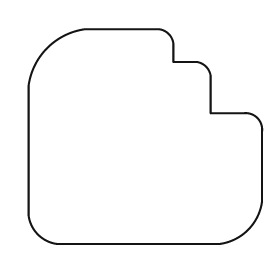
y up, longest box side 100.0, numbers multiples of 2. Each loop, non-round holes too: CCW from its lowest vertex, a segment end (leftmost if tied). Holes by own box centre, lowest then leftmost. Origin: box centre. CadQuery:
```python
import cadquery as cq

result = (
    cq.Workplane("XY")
    .moveTo(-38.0, -46.0)
    .lineTo(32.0, -46.0)
    .threePointArc((44.0, -40.0), (50.0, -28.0))
    .lineTo(50.0, 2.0)
    .threePointArc((48.0, 8.0), (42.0, 10.0))
    .lineTo(28.0, 10.0)
    .lineTo(28.0, 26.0)
    .threePointArc((26.0, 30.0), (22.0, 32.0))
    .lineTo(12.0, 32.0)
    .lineTo(12.0, 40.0)
    .threePointArc((10.0, 44.0), (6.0, 46.0))
    .lineTo(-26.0, 46.0)
    .threePointArc((-42.0, 38.0), (-50.0, 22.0))
    .lineTo(-50.0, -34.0)
    .threePointArc((-46.0, -42.0), (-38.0, -46.0))
    .close()
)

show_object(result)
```